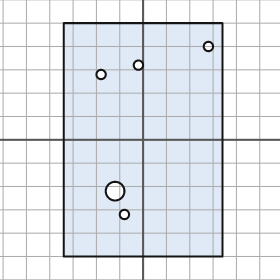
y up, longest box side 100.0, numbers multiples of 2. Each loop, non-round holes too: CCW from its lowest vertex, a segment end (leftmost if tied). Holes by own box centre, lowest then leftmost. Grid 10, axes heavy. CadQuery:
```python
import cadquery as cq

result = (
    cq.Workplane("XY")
    .moveTo(-34.0, -50.0)
    .lineTo(34.0, -50.0)
    .lineTo(34.0, 50.0)
    .lineTo(-34.0, 50.0)
    .close()
    .moveTo(-8.0, -32.0)
    .circle(2.0)
    .moveTo(-12.0, -22.0)
    .circle(4.0)
    .moveTo(-18.0, 28.0)
    .circle(2.0)
    .moveTo(-2.0, 32.0)
    .circle(2.0)
    .moveTo(28.0, 40.0)
    .circle(2.0)
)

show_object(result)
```